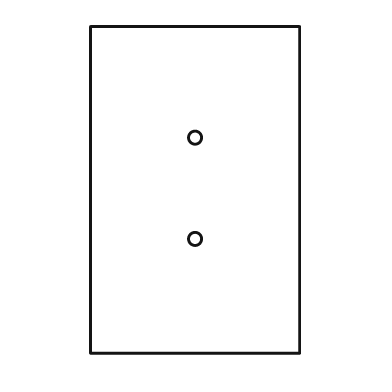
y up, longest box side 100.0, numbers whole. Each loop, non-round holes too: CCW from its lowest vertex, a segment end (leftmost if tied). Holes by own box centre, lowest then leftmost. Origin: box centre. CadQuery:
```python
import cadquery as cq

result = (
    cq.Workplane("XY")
    .moveTo(-32.0, -50.0)
    .lineTo(32.0, -50.0)
    .lineTo(32.0, 50.0)
    .lineTo(-32.0, 50.0)
    .close()
    .moveTo(0.0, -15.0)
    .circle(2.0)
    .moveTo(0.0, 16.0)
    .circle(2.0)
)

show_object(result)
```